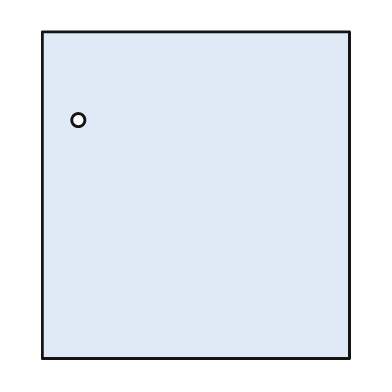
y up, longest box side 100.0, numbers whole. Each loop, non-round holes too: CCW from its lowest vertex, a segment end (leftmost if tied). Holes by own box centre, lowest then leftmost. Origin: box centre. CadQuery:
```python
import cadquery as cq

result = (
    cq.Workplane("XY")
    .moveTo(-47.0, -50.0)
    .lineTo(47.0, -50.0)
    .lineTo(47.0, 50.0)
    .lineTo(-47.0, 50.0)
    .close()
    .moveTo(-36.0, 23.0)
    .circle(2.0)
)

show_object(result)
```